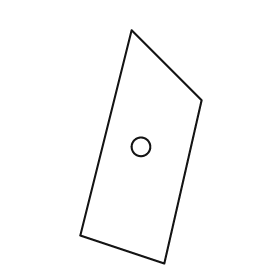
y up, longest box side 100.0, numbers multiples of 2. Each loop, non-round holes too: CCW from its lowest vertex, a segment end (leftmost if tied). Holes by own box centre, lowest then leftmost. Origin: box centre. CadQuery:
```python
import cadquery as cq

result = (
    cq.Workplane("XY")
    .moveTo(10.0, -50.0)
    .lineTo(26.0, 20.0)
    .lineTo(-4.0, 50.0)
    .lineTo(-26.0, -38.0)
    .close()
    .moveTo(0.0, 0.0)
    .circle(4.0)
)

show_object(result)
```